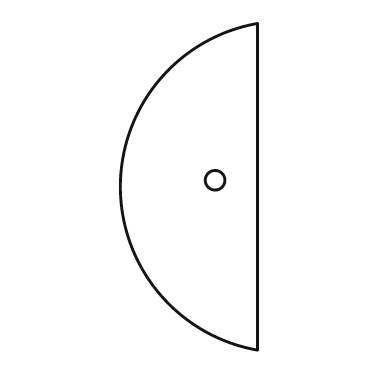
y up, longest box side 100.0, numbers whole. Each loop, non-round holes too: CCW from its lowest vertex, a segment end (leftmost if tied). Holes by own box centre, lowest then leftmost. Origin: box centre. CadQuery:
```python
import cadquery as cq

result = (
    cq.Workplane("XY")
    .moveTo(21.0, -50.0)
    .lineTo(21.0, 50.0)
    .threePointArc((-21.0, 0.0), (21.0, -50.0))
    .close()
    .moveTo(8.0, 2.0)
    .circle(3.0)
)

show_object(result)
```